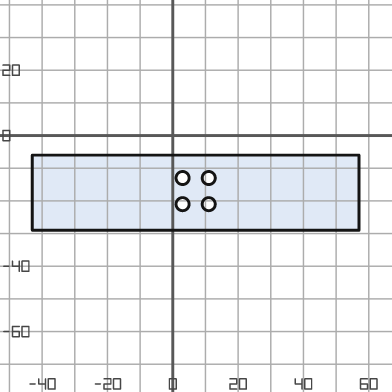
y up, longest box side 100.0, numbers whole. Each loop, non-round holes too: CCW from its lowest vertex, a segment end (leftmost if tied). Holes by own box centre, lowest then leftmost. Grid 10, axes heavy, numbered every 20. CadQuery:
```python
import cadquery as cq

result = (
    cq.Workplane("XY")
    .moveTo(-43.0, -29.0)
    .lineTo(57.0, -29.0)
    .lineTo(57.0, -6.0)
    .lineTo(-43.0, -6.0)
    .close()
    .moveTo(3.0, -21.0)
    .circle(2.0)
    .moveTo(11.0, -21.0)
    .circle(2.0)
    .moveTo(3.0, -13.0)
    .circle(2.0)
    .moveTo(11.0, -13.0)
    .circle(2.0)
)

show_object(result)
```